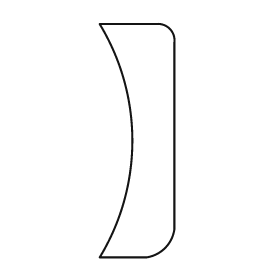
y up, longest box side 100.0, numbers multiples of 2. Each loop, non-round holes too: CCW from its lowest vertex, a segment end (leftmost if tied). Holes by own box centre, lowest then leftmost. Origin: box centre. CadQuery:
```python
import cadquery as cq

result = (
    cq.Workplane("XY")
    .moveTo(-16.0, -50.0)
    .lineTo(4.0, -50.0)
    .threePointArc((12.0, -46.0), (16.0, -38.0))
    .lineTo(16.0, 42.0)
    .threePointArc((14.0, 48.0), (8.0, 50.0))
    .lineTo(-16.0, 50.0)
    .threePointArc((-2.0, 0.0), (-16.0, -50.0))
    .close()
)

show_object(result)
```